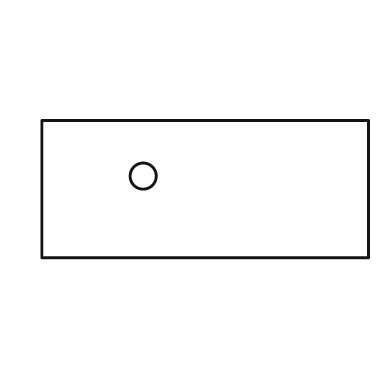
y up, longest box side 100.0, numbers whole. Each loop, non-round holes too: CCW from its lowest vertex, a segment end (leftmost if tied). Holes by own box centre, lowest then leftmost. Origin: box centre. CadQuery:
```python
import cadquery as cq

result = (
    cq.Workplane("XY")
    .moveTo(-50.0, -21.0)
    .lineTo(50.0, -21.0)
    .lineTo(50.0, 21.0)
    .lineTo(-50.0, 21.0)
    .close()
    .moveTo(-19.0, 4.0)
    .circle(4.0)
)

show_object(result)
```